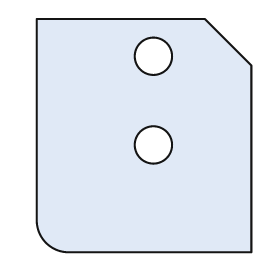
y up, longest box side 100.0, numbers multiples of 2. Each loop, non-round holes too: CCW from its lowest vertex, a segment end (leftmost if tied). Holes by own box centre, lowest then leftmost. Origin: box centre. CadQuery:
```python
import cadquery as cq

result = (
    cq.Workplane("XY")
    .moveTo(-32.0, -50.0)
    .lineTo(46.0, -50.0)
    .lineTo(46.0, 30.0)
    .lineTo(26.0, 50.0)
    .lineTo(-46.0, 50.0)
    .lineTo(-46.0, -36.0)
    .threePointArc((-42.0, -46.0), (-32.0, -50.0))
    .close()
    .moveTo(4.0, -4.0)
    .circle(8.0)
    .moveTo(4.0, 34.0)
    .circle(8.0)
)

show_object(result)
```